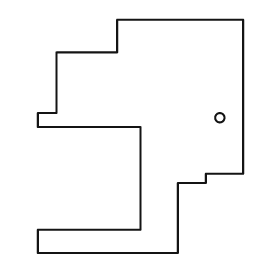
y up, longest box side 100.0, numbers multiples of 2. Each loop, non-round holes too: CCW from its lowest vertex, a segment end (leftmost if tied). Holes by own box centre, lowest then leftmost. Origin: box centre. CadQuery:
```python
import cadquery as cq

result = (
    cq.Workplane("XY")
    .moveTo(-44.0, -50.0)
    .lineTo(16.0, -50.0)
    .lineTo(16.0, -20.0)
    .lineTo(28.0, -20.0)
    .lineTo(28.0, -16.0)
    .lineTo(44.0, -16.0)
    .lineTo(44.0, 50.0)
    .lineTo(-10.0, 50.0)
    .lineTo(-10.0, 36.0)
    .lineTo(-36.0, 36.0)
    .lineTo(-36.0, 10.0)
    .lineTo(-44.0, 10.0)
    .lineTo(-44.0, 4.0)
    .lineTo(0.0, 4.0)
    .lineTo(0.0, -40.0)
    .lineTo(-44.0, -40.0)
    .close()
    .moveTo(34.0, 8.0)
    .circle(2.0)
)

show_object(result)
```